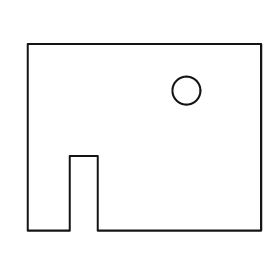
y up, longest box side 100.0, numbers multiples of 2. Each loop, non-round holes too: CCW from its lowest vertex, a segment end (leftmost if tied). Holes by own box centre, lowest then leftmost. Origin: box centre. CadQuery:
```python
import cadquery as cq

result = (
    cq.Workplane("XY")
    .moveTo(-50.0, -40.0)
    .lineTo(-32.0, -40.0)
    .lineTo(-32.0, -8.0)
    .lineTo(-20.0, -8.0)
    .lineTo(-20.0, -40.0)
    .lineTo(50.0, -40.0)
    .lineTo(50.0, 40.0)
    .lineTo(-50.0, 40.0)
    .close()
    .moveTo(18.0, 20.0)
    .circle(6.0)
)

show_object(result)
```